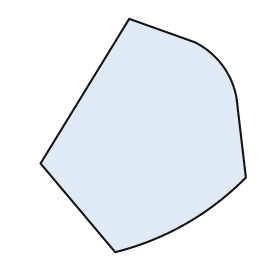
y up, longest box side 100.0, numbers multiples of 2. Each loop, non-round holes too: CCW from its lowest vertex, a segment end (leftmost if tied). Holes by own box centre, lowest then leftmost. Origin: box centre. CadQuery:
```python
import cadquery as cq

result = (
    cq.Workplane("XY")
    .moveTo(-12.0, -50.0)
    .threePointArc((18.0, -38.0), (44.0, -18.0))
    .lineTo(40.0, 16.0)
    .threePointArc((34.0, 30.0), (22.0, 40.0))
    .lineTo(-6.0, 50.0)
    .lineTo(-44.0, -12.0)
    .close()
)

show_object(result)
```